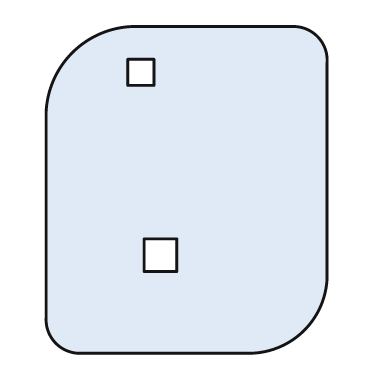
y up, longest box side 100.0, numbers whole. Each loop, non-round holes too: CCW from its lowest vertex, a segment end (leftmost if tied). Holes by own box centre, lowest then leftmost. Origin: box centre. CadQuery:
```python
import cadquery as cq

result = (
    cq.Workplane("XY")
    .moveTo(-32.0, -50.0)
    .lineTo(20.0, -50.0)
    .threePointArc((36.0, -43.0), (43.0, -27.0))
    .lineTo(43.0, 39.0)
    .threePointArc((40.0, 47.0), (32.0, 50.0))
    .lineTo(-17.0, 50.0)
    .threePointArc((-35.0, 42.0), (-43.0, 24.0))
    .lineTo(-43.0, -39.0)
    .threePointArc((-40.0, -47.0), (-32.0, -50.0))
    .close()
    .moveTo(-13.0, -25.0)
    .lineTo(-3.0, -25.0)
    .lineTo(-3.0, -15.0)
    .lineTo(-13.0, -15.0)
    .close()
    .moveTo(-18.0, 32.0)
    .lineTo(-10.0, 32.0)
    .lineTo(-10.0, 40.0)
    .lineTo(-18.0, 40.0)
    .close()
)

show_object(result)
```